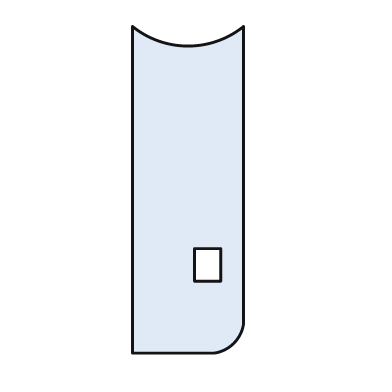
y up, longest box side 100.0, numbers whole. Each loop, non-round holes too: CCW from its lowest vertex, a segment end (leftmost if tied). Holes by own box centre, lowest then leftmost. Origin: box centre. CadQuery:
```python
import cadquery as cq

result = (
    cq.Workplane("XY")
    .moveTo(-17.0, -50.0)
    .lineTo(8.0, -50.0)
    .threePointArc((14.0, -47.0), (17.0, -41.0))
    .lineTo(17.0, 50.0)
    .threePointArc((0.0, 44.0), (-17.0, 50.0))
    .close()
    .moveTo(2.0, -28.0)
    .lineTo(10.0, -28.0)
    .lineTo(10.0, -18.0)
    .lineTo(2.0, -18.0)
    .close()
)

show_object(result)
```